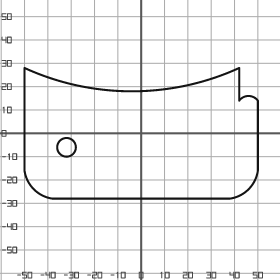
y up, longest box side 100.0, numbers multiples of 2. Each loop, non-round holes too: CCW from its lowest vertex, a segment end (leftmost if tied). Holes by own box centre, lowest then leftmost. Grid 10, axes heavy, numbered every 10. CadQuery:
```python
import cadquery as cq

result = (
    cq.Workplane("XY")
    .moveTo(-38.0, -28.0)
    .lineTo(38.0, -28.0)
    .threePointArc((46.0, -24.0), (50.0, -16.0))
    .lineTo(50.0, 14.0)
    .threePointArc((46.0, 16.0), (42.0, 14.0))
    .lineTo(42.0, 28.0)
    .threePointArc((-4.0, 18.0), (-50.0, 28.0))
    .lineTo(-50.0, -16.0)
    .threePointArc((-46.0, -24.0), (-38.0, -28.0))
    .close()
    .moveTo(-32.0, -6.0)
    .circle(4.0)
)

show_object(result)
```